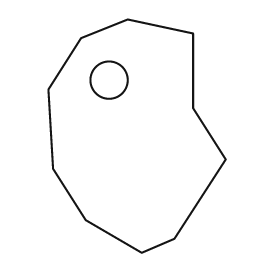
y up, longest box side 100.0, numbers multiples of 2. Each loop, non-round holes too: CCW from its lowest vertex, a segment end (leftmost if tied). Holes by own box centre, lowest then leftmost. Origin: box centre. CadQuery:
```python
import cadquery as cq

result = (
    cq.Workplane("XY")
    .moveTo(2.0, -50.0)
    .lineTo(16.0, -44.0)
    .lineTo(38.0, -10.0)
    .lineTo(24.0, 12.0)
    .lineTo(24.0, 44.0)
    .lineTo(-4.0, 50.0)
    .lineTo(-24.0, 42.0)
    .lineTo(-38.0, 20.0)
    .lineTo(-36.0, -14.0)
    .lineTo(-22.0, -36.0)
    .close()
    .moveTo(-12.0, 24.0)
    .circle(8.0)
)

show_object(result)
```